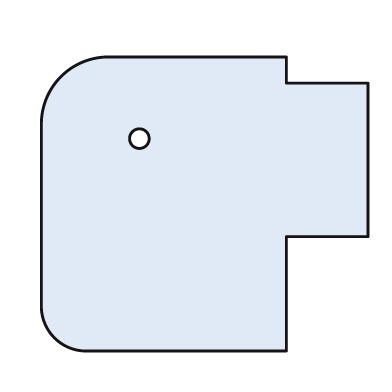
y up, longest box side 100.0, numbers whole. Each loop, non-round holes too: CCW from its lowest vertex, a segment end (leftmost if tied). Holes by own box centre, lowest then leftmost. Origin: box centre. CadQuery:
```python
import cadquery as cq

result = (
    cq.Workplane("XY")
    .moveTo(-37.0, -45.0)
    .lineTo(25.0, -45.0)
    .lineTo(25.0, -10.0)
    .lineTo(50.0, -10.0)
    .lineTo(50.0, 37.0)
    .lineTo(25.0, 37.0)
    .lineTo(25.0, 45.0)
    .lineTo(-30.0, 45.0)
    .threePointArc((-44.0, 39.0), (-50.0, 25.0))
    .lineTo(-50.0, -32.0)
    .threePointArc((-46.0, -41.0), (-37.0, -45.0))
    .close()
    .moveTo(-20.0, 20.0)
    .circle(3.0)
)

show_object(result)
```